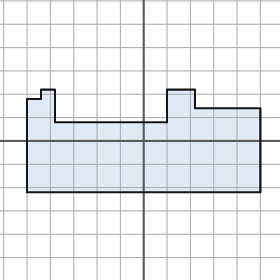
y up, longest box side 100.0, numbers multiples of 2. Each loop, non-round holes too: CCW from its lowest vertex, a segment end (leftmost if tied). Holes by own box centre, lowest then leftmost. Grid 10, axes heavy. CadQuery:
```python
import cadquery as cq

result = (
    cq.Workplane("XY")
    .moveTo(-50.0, -22.0)
    .lineTo(50.0, -22.0)
    .lineTo(50.0, 14.0)
    .lineTo(22.0, 14.0)
    .lineTo(22.0, 22.0)
    .lineTo(10.0, 22.0)
    .lineTo(10.0, 8.0)
    .lineTo(-38.0, 8.0)
    .lineTo(-38.0, 22.0)
    .lineTo(-44.0, 22.0)
    .lineTo(-44.0, 18.0)
    .lineTo(-50.0, 18.0)
    .close()
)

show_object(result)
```